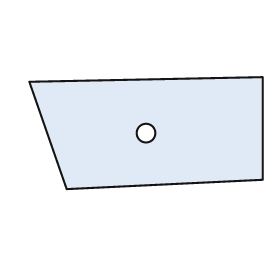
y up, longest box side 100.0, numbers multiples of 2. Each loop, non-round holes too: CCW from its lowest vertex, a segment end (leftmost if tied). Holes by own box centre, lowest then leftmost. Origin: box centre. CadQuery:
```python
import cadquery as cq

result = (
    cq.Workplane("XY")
    .moveTo(-34.0, -24.0)
    .lineTo(50.0, -20.0)
    .lineTo(50.0, 24.0)
    .lineTo(-50.0, 22.0)
    .close()
    .moveTo(0.0, 0.0)
    .circle(4.0)
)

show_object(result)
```